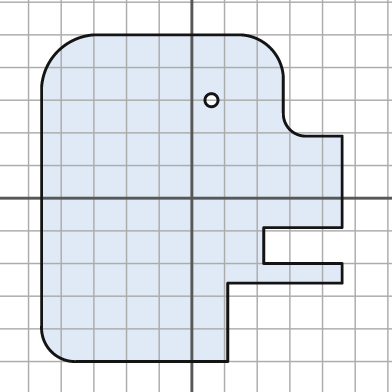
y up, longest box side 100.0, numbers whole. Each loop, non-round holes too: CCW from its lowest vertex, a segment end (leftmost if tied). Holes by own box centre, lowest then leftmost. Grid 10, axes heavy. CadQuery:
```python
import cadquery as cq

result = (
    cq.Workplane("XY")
    .moveTo(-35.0, -50.0)
    .lineTo(11.0, -50.0)
    .lineTo(11.0, -26.0)
    .lineTo(46.0, -26.0)
    .lineTo(46.0, -20.0)
    .lineTo(22.0, -20.0)
    .lineTo(22.0, -9.0)
    .lineTo(46.0, -9.0)
    .lineTo(46.0, 19.0)
    .lineTo(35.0, 19.0)
    .threePointArc((30.0, 21.0), (28.0, 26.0))
    .lineTo(28.0, 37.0)
    .threePointArc((24.0, 46.0), (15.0, 50.0))
    .lineTo(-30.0, 50.0)
    .threePointArc((-41.0, 45.0), (-46.0, 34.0))
    .lineTo(-46.0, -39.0)
    .threePointArc((-43.0, -47.0), (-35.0, -50.0))
    .close()
    .moveTo(6.0, 30.0)
    .circle(2.0)
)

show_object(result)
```